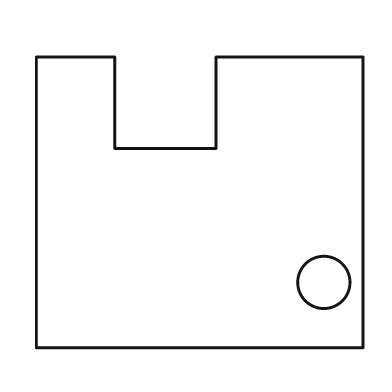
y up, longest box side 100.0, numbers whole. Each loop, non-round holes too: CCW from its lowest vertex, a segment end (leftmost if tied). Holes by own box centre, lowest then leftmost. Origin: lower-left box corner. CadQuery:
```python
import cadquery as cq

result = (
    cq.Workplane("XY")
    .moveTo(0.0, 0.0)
    .lineTo(100.0, 0.0)
    .lineTo(100.0, 89.0)
    .lineTo(55.0, 89.0)
    .lineTo(55.0, 61.0)
    .lineTo(24.0, 61.0)
    .lineTo(24.0, 89.0)
    .lineTo(0.0, 89.0)
    .close()
    .moveTo(88.0, 20.0)
    .circle(8.0)
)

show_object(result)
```